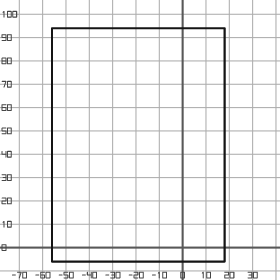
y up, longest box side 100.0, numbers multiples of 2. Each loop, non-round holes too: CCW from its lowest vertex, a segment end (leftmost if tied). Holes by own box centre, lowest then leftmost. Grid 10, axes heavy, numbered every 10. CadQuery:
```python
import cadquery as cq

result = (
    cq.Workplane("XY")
    .moveTo(-56.0, -6.0)
    .lineTo(18.0, -6.0)
    .lineTo(18.0, 94.0)
    .lineTo(-56.0, 94.0)
    .close()
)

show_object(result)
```